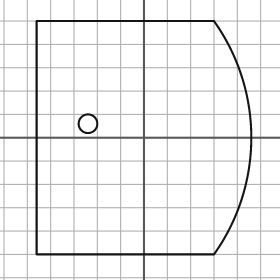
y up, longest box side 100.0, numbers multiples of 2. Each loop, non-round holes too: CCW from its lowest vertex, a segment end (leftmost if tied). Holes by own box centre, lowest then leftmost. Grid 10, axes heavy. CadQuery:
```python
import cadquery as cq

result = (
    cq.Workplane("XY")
    .moveTo(-46.0, -50.0)
    .lineTo(30.0, -50.0)
    .threePointArc((46.0, 0.0), (30.0, 50.0))
    .lineTo(-46.0, 50.0)
    .close()
    .moveTo(-24.0, 6.0)
    .circle(4.0)
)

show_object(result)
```